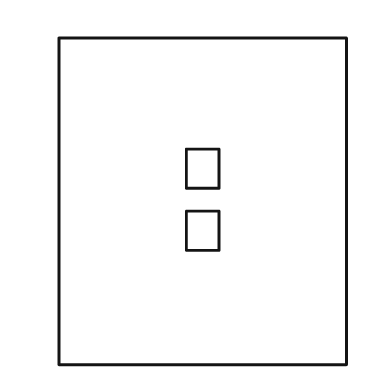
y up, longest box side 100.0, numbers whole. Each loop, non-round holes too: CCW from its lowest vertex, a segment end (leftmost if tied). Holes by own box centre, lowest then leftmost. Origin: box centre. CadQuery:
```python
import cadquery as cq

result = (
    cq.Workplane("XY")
    .moveTo(-44.0, -50.0)
    .lineTo(44.0, -50.0)
    .lineTo(44.0, 50.0)
    .lineTo(-44.0, 50.0)
    .close()
    .moveTo(-5.0, -15.0)
    .lineTo(5.0, -15.0)
    .lineTo(5.0, -3.0)
    .lineTo(-5.0, -3.0)
    .close()
    .moveTo(-5.0, 4.0)
    .lineTo(5.0, 4.0)
    .lineTo(5.0, 16.0)
    .lineTo(-5.0, 16.0)
    .close()
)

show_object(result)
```